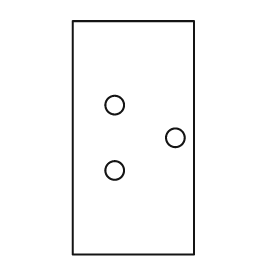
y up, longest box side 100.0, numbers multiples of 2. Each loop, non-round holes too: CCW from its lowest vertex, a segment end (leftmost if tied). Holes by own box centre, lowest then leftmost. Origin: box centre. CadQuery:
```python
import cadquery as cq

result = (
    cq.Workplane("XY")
    .moveTo(-26.0, -50.0)
    .lineTo(26.0, -50.0)
    .lineTo(26.0, 50.0)
    .lineTo(-26.0, 50.0)
    .close()
    .moveTo(-8.0, -14.0)
    .circle(4.0)
    .moveTo(18.0, 0.0)
    .circle(4.0)
    .moveTo(-8.0, 14.0)
    .circle(4.0)
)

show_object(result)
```